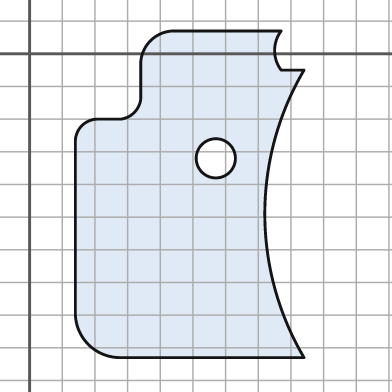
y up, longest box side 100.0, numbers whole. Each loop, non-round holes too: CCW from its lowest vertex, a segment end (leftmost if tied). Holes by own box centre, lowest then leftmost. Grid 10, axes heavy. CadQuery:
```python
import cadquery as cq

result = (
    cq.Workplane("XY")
    .moveTo(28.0, -93.0)
    .lineTo(84.0, -93.0)
    .threePointArc((72.0, -49.0), (84.0, -5.0))
    .lineTo(77.0, -5.0)
    .threePointArc((75.0, 1.0), (77.0, 7.0))
    .lineTo(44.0, 7.0)
    .threePointArc((37.0, 4.0), (34.0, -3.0))
    .lineTo(34.0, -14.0)
    .threePointArc((32.0, -18.0), (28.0, -20.0))
    .lineTo(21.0, -20.0)
    .threePointArc((16.0, -22.0), (14.0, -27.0))
    .lineTo(14.0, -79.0)
    .threePointArc((18.0, -89.0), (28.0, -93.0))
    .close()
    .moveTo(57.0, -32.0)
    .circle(6.0)
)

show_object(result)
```